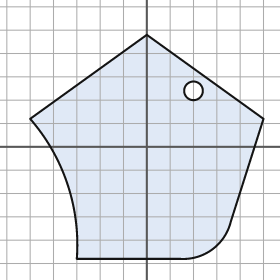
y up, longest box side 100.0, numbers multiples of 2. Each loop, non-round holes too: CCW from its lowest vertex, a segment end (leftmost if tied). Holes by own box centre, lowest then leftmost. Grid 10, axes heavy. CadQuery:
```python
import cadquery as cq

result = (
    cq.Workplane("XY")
    .moveTo(-30.0, -48.0)
    .lineTo(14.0, -48.0)
    .threePointArc((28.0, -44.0), (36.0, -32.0))
    .lineTo(50.0, 12.0)
    .lineTo(0.0, 48.0)
    .lineTo(-50.0, 12.0)
    .threePointArc((-34.0, -16.0), (-30.0, -48.0))
    .close()
    .moveTo(20.0, 24.0)
    .circle(4.0)
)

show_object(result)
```